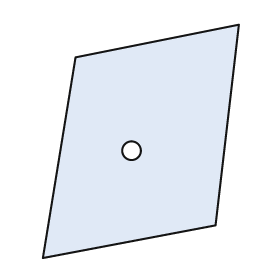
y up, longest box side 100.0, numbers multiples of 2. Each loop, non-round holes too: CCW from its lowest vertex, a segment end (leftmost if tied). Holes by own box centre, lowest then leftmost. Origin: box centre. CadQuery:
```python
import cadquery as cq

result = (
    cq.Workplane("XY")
    .moveTo(-42.0, -50.0)
    .lineTo(32.0, -36.0)
    .lineTo(42.0, 50.0)
    .lineTo(-28.0, 36.0)
    .close()
    .moveTo(-4.0, -4.0)
    .circle(4.0)
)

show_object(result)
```